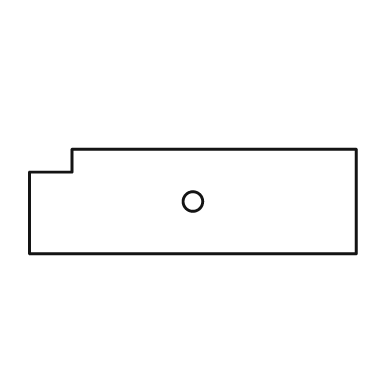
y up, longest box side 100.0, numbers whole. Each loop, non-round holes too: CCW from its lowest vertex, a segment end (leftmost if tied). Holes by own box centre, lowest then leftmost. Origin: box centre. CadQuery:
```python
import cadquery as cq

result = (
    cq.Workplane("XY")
    .moveTo(-50.0, -16.0)
    .lineTo(50.0, -16.0)
    .lineTo(50.0, 16.0)
    .lineTo(-37.0, 16.0)
    .lineTo(-37.0, 9.0)
    .lineTo(-50.0, 9.0)
    .close()
    .moveTo(0.0, 0.0)
    .circle(3.0)
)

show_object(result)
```